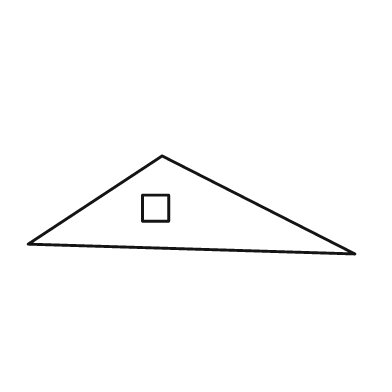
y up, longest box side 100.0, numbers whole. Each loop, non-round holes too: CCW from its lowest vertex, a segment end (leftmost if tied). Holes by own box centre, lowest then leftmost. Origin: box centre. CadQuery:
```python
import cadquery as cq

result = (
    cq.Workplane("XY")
    .moveTo(50.0, -15.0)
    .lineTo(-9.0, 15.0)
    .lineTo(-50.0, -12.0)
    .close()
    .moveTo(-15.0, -5.0)
    .lineTo(-7.0, -5.0)
    .lineTo(-7.0, 3.0)
    .lineTo(-15.0, 3.0)
    .close()
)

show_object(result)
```